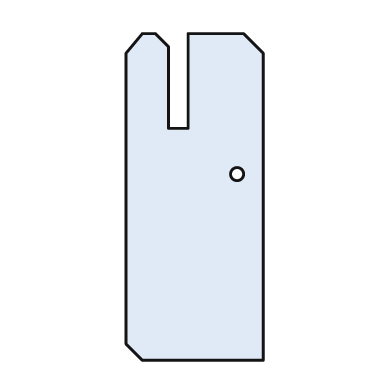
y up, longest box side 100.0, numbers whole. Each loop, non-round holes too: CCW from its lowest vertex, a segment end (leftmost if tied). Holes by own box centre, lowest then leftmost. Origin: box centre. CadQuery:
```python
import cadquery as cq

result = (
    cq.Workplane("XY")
    .moveTo(-16.0, -50.0)
    .lineTo(21.0, -50.0)
    .lineTo(21.0, 44.0)
    .lineTo(15.0, 50.0)
    .lineTo(-2.0, 50.0)
    .lineTo(-2.0, 21.0)
    .lineTo(-8.0, 21.0)
    .lineTo(-8.0, 46.0)
    .lineTo(-12.0, 50.0)
    .lineTo(-16.0, 50.0)
    .lineTo(-21.0, 44.0)
    .lineTo(-21.0, -45.0)
    .close()
    .moveTo(13.0, 7.0)
    .circle(2.0)
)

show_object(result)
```